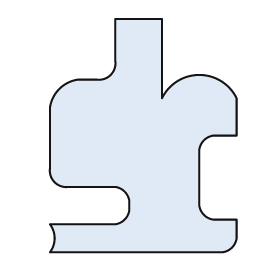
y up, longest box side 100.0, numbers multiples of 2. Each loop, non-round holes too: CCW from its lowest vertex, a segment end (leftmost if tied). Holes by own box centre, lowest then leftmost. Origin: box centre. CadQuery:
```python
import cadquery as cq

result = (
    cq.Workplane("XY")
    .moveTo(-40.0, -50.0)
    .lineTo(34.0, -50.0)
    .threePointArc((38.0, -48.0), (40.0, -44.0))
    .lineTo(40.0, -36.0)
    .lineTo(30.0, -36.0)
    .threePointArc((26.0, -34.0), (24.0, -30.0))
    .lineTo(24.0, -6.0)
    .threePointArc((26.0, -2.0), (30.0, 0.0))
    .lineTo(40.0, 0.0)
    .lineTo(40.0, 16.0)
    .threePointArc((24.0, 26.0), (8.0, 16.0))
    .lineTo(8.0, 50.0)
    .lineTo(-12.0, 50.0)
    .lineTo(-12.0, 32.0)
    .threePointArc((-14.0, 26.0), (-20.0, 24.0))
    .lineTo(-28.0, 24.0)
    .threePointArc((-36.0, 20.0), (-40.0, 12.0))
    .lineTo(-40.0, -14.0)
    .threePointArc((-38.0, -20.0), (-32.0, -22.0))
    .lineTo(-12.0, -22.0)
    .threePointArc((-8.0, -24.0), (-6.0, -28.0))
    .lineTo(-6.0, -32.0)
    .threePointArc((-8.0, -36.0), (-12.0, -38.0))
    .lineTo(-40.0, -38.0)
    .threePointArc((-38.0, -44.0), (-40.0, -50.0))
    .close()
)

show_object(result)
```